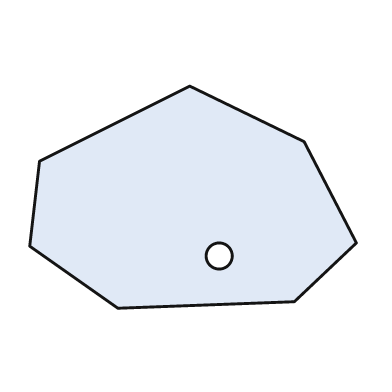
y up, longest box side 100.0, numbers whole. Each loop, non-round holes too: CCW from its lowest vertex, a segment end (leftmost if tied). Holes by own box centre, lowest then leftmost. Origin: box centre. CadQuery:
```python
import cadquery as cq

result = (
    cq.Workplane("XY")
    .moveTo(-23.0, -34.0)
    .lineTo(31.0, -32.0)
    .lineTo(50.0, -14.0)
    .lineTo(34.0, 17.0)
    .lineTo(-1.0, 34.0)
    .lineTo(-47.0, 11.0)
    .lineTo(-50.0, -15.0)
    .close()
    .moveTo(8.0, -18.0)
    .circle(4.0)
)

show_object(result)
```